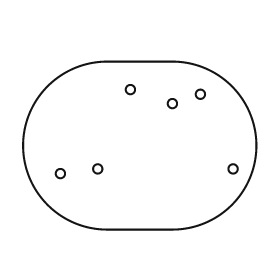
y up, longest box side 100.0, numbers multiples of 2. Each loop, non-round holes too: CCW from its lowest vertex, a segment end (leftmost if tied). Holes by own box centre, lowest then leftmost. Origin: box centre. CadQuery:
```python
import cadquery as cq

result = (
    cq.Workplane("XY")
    .moveTo(-14.0, -36.0)
    .lineTo(14.0, -36.0)
    .threePointArc((50.0, 0.0), (14.0, 36.0))
    .lineTo(-14.0, 36.0)
    .threePointArc((-50.0, 0.0), (-14.0, -36.0))
    .close()
    .moveTo(-34.0, -12.0)
    .circle(2.0)
    .moveTo(-18.0, -10.0)
    .circle(2.0)
    .moveTo(40.0, -10.0)
    .circle(2.0)
    .moveTo(14.0, 18.0)
    .circle(2.0)
    .moveTo(26.0, 22.0)
    .circle(2.0)
    .moveTo(-4.0, 24.0)
    .circle(2.0)
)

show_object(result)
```